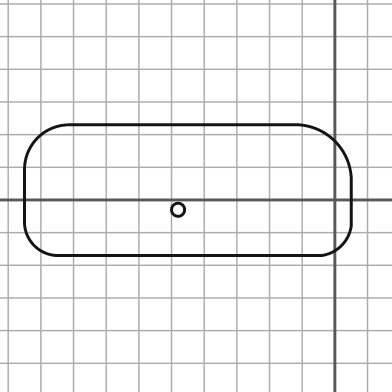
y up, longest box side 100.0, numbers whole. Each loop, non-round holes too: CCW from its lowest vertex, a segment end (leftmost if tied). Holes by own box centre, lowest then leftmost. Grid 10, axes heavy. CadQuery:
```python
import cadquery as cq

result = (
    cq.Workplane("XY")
    .moveTo(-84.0, -17.0)
    .lineTo(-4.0, -17.0)
    .threePointArc((2.0, -14.0), (5.0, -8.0))
    .lineTo(5.0, 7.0)
    .threePointArc((0.0, 18.0), (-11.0, 23.0))
    .lineTo(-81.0, 23.0)
    .threePointArc((-91.0, 19.0), (-95.0, 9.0))
    .lineTo(-95.0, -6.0)
    .threePointArc((-92.0, -14.0), (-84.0, -17.0))
    .close()
    .moveTo(-48.0, -3.0)
    .circle(2.0)
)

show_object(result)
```